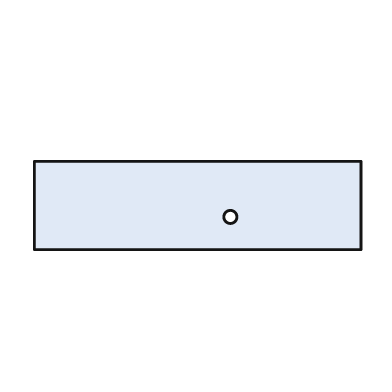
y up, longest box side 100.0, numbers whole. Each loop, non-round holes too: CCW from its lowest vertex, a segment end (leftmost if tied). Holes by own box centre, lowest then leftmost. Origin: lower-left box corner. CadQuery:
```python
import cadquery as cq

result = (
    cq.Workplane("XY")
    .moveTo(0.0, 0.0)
    .lineTo(100.0, 0.0)
    .lineTo(100.0, 27.0)
    .lineTo(0.0, 27.0)
    .close()
    .moveTo(60.0, 10.0)
    .circle(2.0)
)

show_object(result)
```